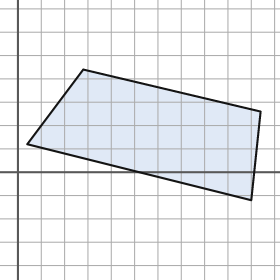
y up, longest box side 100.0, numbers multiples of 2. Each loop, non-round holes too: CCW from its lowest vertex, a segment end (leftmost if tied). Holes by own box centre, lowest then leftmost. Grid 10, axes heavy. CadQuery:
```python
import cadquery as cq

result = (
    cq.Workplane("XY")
    .moveTo(100.0, -12.0)
    .lineTo(104.0, 26.0)
    .lineTo(28.0, 44.0)
    .lineTo(4.0, 12.0)
    .close()
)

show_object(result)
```